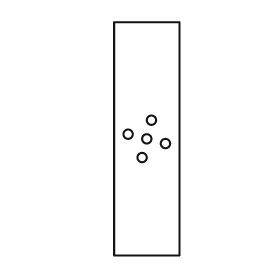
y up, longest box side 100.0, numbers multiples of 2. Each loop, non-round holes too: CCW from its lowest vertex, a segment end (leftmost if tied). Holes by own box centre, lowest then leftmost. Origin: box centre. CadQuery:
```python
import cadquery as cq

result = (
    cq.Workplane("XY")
    .moveTo(-14.0, -50.0)
    .lineTo(14.0, -50.0)
    .lineTo(14.0, 50.0)
    .lineTo(-14.0, 50.0)
    .close()
    .moveTo(-2.0, -8.0)
    .circle(2.0)
    .moveTo(8.0, -2.0)
    .circle(2.0)
    .moveTo(0.0, 0.0)
    .circle(2.0)
    .moveTo(-8.0, 2.0)
    .circle(2.0)
    .moveTo(2.0, 8.0)
    .circle(2.0)
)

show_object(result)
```